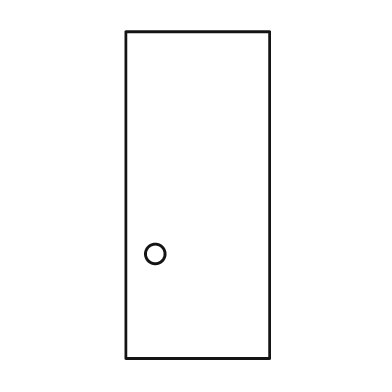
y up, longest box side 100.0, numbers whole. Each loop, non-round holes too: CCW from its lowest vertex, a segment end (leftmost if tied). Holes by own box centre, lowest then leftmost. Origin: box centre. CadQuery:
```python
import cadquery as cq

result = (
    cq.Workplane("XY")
    .moveTo(-22.0, -50.0)
    .lineTo(22.0, -50.0)
    .lineTo(22.0, 50.0)
    .lineTo(-22.0, 50.0)
    .close()
    .moveTo(-13.0, -18.0)
    .circle(3.0)
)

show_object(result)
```